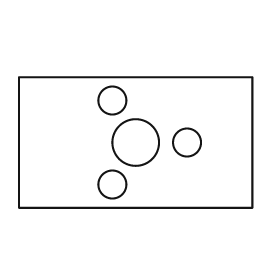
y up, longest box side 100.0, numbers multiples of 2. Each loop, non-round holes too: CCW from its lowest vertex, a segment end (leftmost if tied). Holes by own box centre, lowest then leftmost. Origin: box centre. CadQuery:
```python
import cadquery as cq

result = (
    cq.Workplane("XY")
    .moveTo(-50.0, -28.0)
    .lineTo(50.0, -28.0)
    .lineTo(50.0, 28.0)
    .lineTo(-50.0, 28.0)
    .close()
    .moveTo(-10.0, -18.0)
    .circle(6.0)
    .moveTo(0.0, 0.0)
    .circle(10.0)
    .moveTo(22.0, 0.0)
    .circle(6.0)
    .moveTo(-10.0, 18.0)
    .circle(6.0)
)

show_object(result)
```